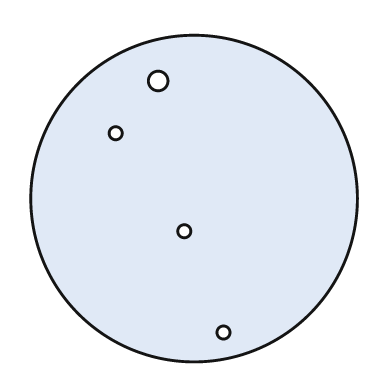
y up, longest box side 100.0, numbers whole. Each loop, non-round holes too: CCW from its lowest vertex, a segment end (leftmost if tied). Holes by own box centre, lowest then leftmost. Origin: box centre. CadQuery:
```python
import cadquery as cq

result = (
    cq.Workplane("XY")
    .moveTo(0.0, 0.0)
    .circle(50.0)
    .moveTo(9.0, -41.0)
    .circle(2.0)
    .moveTo(-3.0, -10.0)
    .circle(2.0)
    .moveTo(-24.0, 20.0)
    .circle(2.0)
    .moveTo(-11.0, 36.0)
    .circle(3.0)
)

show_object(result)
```